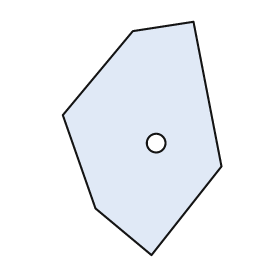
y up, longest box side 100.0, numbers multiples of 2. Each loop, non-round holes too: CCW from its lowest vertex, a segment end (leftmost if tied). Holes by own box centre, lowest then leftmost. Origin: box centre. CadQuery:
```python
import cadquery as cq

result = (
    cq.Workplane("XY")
    .moveTo(4.0, -50.0)
    .lineTo(34.0, -12.0)
    .lineTo(22.0, 50.0)
    .lineTo(-4.0, 46.0)
    .lineTo(-34.0, 10.0)
    .lineTo(-20.0, -30.0)
    .close()
    .moveTo(6.0, -2.0)
    .circle(4.0)
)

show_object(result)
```